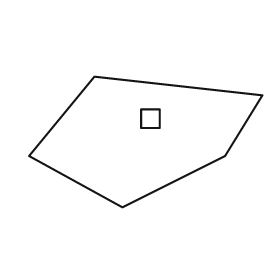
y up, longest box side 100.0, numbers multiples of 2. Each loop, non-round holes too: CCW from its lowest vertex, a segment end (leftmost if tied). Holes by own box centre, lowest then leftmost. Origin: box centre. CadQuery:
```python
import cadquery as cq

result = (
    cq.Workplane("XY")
    .moveTo(-10.0, -28.0)
    .lineTo(34.0, -6.0)
    .lineTo(50.0, 20.0)
    .lineTo(-22.0, 28.0)
    .lineTo(-50.0, -6.0)
    .close()
    .moveTo(-2.0, 6.0)
    .lineTo(6.0, 6.0)
    .lineTo(6.0, 14.0)
    .lineTo(-2.0, 14.0)
    .close()
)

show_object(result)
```